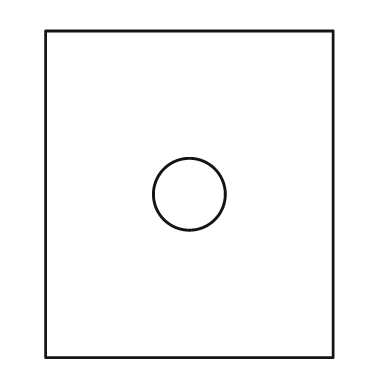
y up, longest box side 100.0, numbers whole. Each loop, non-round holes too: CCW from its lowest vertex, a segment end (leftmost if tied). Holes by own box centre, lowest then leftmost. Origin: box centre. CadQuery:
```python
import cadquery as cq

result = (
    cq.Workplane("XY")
    .moveTo(-44.0, -50.0)
    .lineTo(44.0, -50.0)
    .lineTo(44.0, 50.0)
    .lineTo(-44.0, 50.0)
    .close()
    .moveTo(0.0, 0.0)
    .circle(11.0)
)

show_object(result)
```